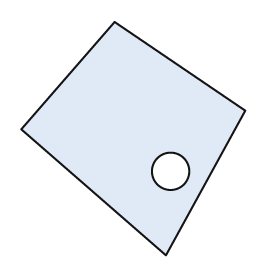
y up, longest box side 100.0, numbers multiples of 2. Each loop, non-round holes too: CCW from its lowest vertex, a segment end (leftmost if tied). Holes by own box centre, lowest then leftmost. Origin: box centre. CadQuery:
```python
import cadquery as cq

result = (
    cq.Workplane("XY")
    .moveTo(14.0, -50.0)
    .lineTo(48.0, 12.0)
    .lineTo(-8.0, 50.0)
    .lineTo(-48.0, 4.0)
    .close()
    .moveTo(16.0, -14.0)
    .circle(8.0)
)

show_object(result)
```